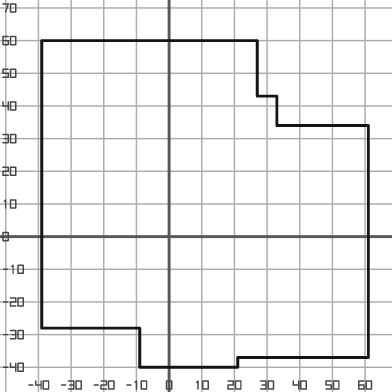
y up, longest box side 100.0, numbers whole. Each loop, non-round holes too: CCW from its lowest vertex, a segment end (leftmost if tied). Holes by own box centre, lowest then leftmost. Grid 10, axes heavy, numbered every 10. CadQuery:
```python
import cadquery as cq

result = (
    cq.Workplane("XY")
    .moveTo(-9.0, -40.0)
    .lineTo(21.0, -40.0)
    .lineTo(21.0, -37.0)
    .lineTo(61.0, -37.0)
    .lineTo(61.0, 34.0)
    .lineTo(33.0, 34.0)
    .lineTo(33.0, 43.0)
    .lineTo(27.0, 43.0)
    .lineTo(27.0, 60.0)
    .lineTo(-39.0, 60.0)
    .lineTo(-39.0, -28.0)
    .lineTo(-9.0, -28.0)
    .close()
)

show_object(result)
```